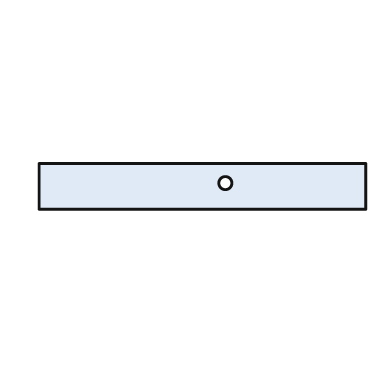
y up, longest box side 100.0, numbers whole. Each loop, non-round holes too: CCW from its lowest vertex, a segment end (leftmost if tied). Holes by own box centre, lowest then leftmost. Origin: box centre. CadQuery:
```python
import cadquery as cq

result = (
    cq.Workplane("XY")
    .moveTo(-50.0, -7.0)
    .lineTo(50.0, -7.0)
    .lineTo(50.0, 7.0)
    .lineTo(-50.0, 7.0)
    .close()
    .moveTo(7.0, 1.0)
    .circle(2.0)
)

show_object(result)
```